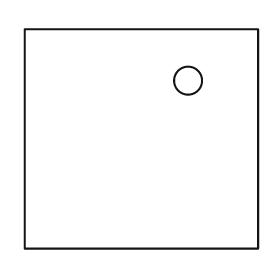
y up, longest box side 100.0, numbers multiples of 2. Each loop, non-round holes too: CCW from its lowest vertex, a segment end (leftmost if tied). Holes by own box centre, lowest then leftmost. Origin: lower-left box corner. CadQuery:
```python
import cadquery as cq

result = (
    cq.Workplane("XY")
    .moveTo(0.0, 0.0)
    .lineTo(100.0, 0.0)
    .lineTo(100.0, 94.0)
    .lineTo(0.0, 94.0)
    .close()
    .moveTo(70.0, 72.0)
    .circle(6.0)
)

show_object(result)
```